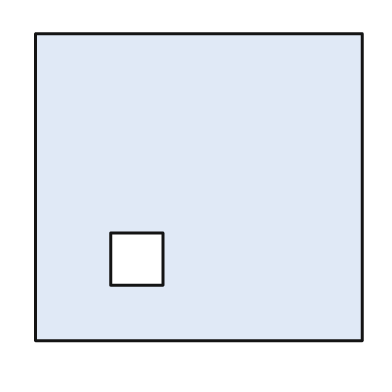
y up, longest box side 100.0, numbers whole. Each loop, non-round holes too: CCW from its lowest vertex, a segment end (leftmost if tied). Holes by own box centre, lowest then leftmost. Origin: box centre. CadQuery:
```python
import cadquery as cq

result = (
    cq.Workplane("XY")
    .moveTo(-50.0, -47.0)
    .lineTo(50.0, -47.0)
    .lineTo(50.0, 47.0)
    .lineTo(-50.0, 47.0)
    .close()
    .moveTo(-27.0, -30.0)
    .lineTo(-11.0, -30.0)
    .lineTo(-11.0, -14.0)
    .lineTo(-27.0, -14.0)
    .close()
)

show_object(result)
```